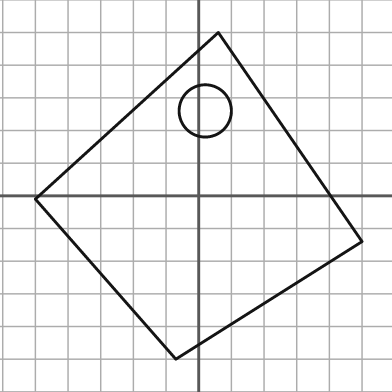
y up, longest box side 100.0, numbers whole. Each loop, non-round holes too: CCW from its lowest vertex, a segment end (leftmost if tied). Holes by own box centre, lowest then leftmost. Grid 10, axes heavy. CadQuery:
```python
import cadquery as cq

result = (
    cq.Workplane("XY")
    .moveTo(-7.0, -50.0)
    .lineTo(50.0, -14.0)
    .lineTo(6.0, 50.0)
    .lineTo(-50.0, -1.0)
    .close()
    .moveTo(2.0, 26.0)
    .circle(8.0)
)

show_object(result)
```